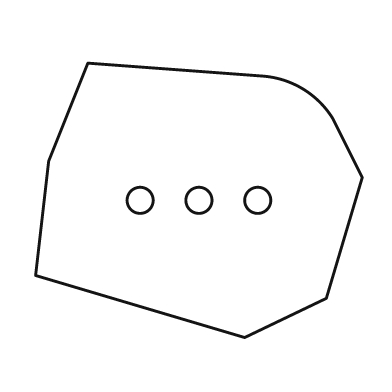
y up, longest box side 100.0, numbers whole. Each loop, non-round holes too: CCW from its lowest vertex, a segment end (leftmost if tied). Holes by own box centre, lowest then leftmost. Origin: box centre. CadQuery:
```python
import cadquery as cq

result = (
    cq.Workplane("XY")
    .moveTo(14.0, -42.0)
    .lineTo(39.0, -30.0)
    .lineTo(50.0, 7.0)
    .lineTo(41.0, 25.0)
    .threePointArc((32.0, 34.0), (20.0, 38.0))
    .lineTo(-34.0, 42.0)
    .lineTo(-46.0, 12.0)
    .lineTo(-50.0, -23.0)
    .close()
    .moveTo(-18.0, 0.0)
    .circle(4.0)
    .moveTo(0.0, 0.0)
    .circle(4.0)
    .moveTo(18.0, 0.0)
    .circle(4.0)
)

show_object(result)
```